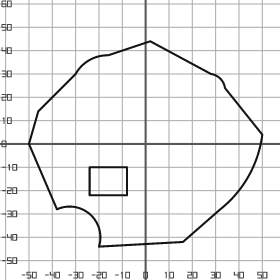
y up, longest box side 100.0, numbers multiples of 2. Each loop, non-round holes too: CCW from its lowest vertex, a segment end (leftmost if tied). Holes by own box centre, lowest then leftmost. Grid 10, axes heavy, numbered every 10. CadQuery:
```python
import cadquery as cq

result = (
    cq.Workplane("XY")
    .moveTo(-20.0, -44.0)
    .lineTo(16.0, -42.0)
    .lineTo(32.0, -28.0)
    .threePointArc((44.0, -14.0), (50.0, 4.0))
    .lineTo(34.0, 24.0)
    .threePointArc((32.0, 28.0), (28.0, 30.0))
    .lineTo(2.0, 44.0)
    .lineTo(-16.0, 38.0)
    .threePointArc((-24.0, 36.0), (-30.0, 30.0))
    .lineTo(-46.0, 14.0)
    .lineTo(-50.0, 0.0)
    .lineTo(-38.0, -28.0)
    .threePointArc((-24.0, -30.0), (-20.0, -44.0))
    .close()
    .moveTo(-24.0, -22.0)
    .lineTo(-8.0, -22.0)
    .lineTo(-8.0, -10.0)
    .lineTo(-24.0, -10.0)
    .close()
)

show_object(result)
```